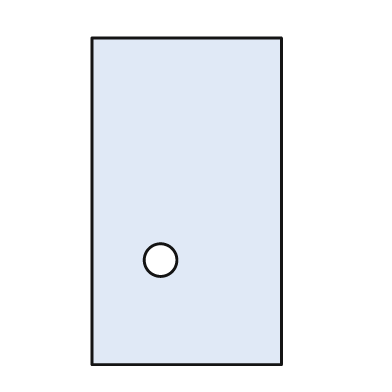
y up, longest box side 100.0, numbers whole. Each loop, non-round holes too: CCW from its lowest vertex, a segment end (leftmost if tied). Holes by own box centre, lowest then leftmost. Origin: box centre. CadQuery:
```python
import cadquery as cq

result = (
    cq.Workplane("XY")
    .moveTo(-29.0, -50.0)
    .lineTo(29.0, -50.0)
    .lineTo(29.0, 50.0)
    .lineTo(-29.0, 50.0)
    .close()
    .moveTo(-8.0, -18.0)
    .circle(5.0)
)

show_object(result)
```